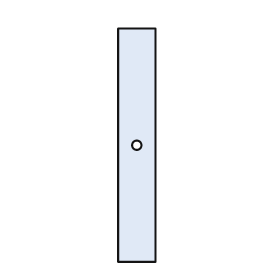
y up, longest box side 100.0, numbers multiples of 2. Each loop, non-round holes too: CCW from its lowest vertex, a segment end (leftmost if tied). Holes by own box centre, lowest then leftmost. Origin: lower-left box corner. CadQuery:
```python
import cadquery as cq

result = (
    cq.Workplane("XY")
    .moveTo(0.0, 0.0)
    .lineTo(16.0, 0.0)
    .lineTo(16.0, 100.0)
    .lineTo(0.0, 100.0)
    .close()
    .moveTo(8.0, 50.0)
    .circle(2.0)
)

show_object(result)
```